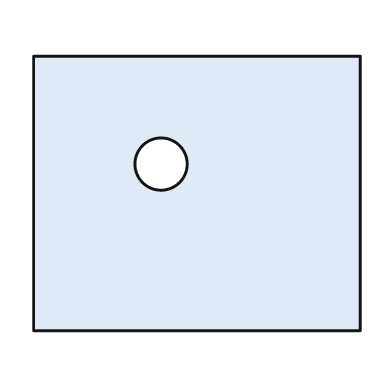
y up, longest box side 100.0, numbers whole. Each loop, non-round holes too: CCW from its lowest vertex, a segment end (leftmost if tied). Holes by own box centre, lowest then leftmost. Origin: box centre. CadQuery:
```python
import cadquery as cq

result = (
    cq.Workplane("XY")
    .moveTo(-50.0, -42.0)
    .lineTo(50.0, -42.0)
    .lineTo(50.0, 42.0)
    .lineTo(-50.0, 42.0)
    .close()
    .moveTo(-11.0, 9.0)
    .circle(8.0)
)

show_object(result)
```